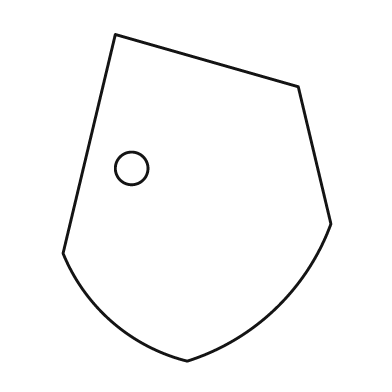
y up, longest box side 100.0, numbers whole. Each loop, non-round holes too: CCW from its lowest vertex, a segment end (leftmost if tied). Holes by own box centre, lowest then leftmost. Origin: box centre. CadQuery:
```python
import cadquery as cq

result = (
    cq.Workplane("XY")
    .moveTo(-3.0, -50.0)
    .threePointArc((24.0, -34.0), (41.0, -8.0))
    .lineTo(31.0, 34.0)
    .lineTo(-25.0, 50.0)
    .lineTo(-41.0, -17.0)
    .threePointArc((-26.0, -38.0), (-3.0, -50.0))
    .close()
    .moveTo(-20.0, 9.0)
    .circle(5.0)
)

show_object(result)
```